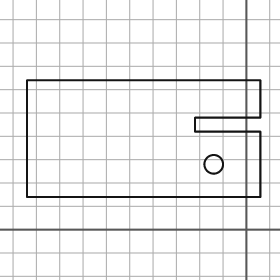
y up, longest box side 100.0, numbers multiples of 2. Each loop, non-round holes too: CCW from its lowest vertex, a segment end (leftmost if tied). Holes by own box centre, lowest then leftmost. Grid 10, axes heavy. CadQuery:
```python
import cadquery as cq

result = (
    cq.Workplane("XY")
    .moveTo(-94.0, 14.0)
    .lineTo(6.0, 14.0)
    .lineTo(6.0, 42.0)
    .lineTo(-22.0, 42.0)
    .lineTo(-22.0, 48.0)
    .lineTo(6.0, 48.0)
    .lineTo(6.0, 64.0)
    .lineTo(-94.0, 64.0)
    .close()
    .moveTo(-14.0, 28.0)
    .circle(4.0)
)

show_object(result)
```